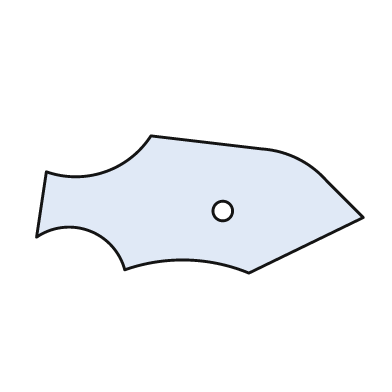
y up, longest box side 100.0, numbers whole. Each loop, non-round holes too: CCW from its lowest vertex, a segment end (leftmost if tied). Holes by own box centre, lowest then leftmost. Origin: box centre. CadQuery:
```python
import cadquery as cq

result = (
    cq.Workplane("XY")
    .moveTo(15.0, -21.0)
    .lineTo(50.0, -4.0)
    .lineTo(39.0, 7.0)
    .threePointArc((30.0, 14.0), (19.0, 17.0))
    .lineTo(-15.0, 21.0)
    .threePointArc((-29.0, 10.0), (-47.0, 10.0))
    .lineTo(-50.0, -10.0)
    .threePointArc((-34.0, -8.0), (-23.0, -20.0))
    .threePointArc((-4.0, -17.0), (15.0, -21.0))
    .close()
    .moveTo(7.0, -2.0)
    .circle(3.0)
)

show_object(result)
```